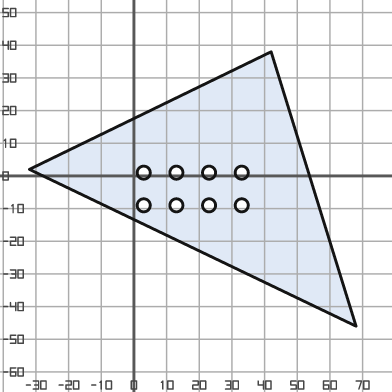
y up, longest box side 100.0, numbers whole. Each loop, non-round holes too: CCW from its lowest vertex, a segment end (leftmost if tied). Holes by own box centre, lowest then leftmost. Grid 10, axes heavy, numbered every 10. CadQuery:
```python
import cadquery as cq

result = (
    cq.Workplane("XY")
    .moveTo(68.0, -46.0)
    .lineTo(42.0, 38.0)
    .lineTo(-32.0, 2.0)
    .close()
    .moveTo(3.0, -9.0)
    .circle(2.0)
    .moveTo(13.0, -9.0)
    .circle(2.0)
    .moveTo(23.0, -9.0)
    .circle(2.0)
    .moveTo(33.0, -9.0)
    .circle(2.0)
    .moveTo(3.0, 1.0)
    .circle(2.0)
    .moveTo(13.0, 1.0)
    .circle(2.0)
    .moveTo(23.0, 1.0)
    .circle(2.0)
    .moveTo(33.0, 1.0)
    .circle(2.0)
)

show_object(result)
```